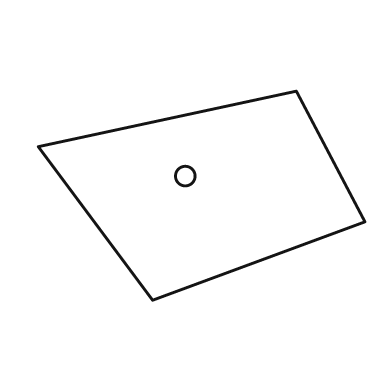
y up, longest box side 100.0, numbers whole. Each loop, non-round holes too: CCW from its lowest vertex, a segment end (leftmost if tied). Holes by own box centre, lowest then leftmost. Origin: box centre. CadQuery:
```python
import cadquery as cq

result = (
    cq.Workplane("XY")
    .moveTo(-15.0, -32.0)
    .lineTo(50.0, -8.0)
    .lineTo(29.0, 32.0)
    .lineTo(-50.0, 15.0)
    .close()
    .moveTo(-5.0, 6.0)
    .circle(3.0)
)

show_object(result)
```